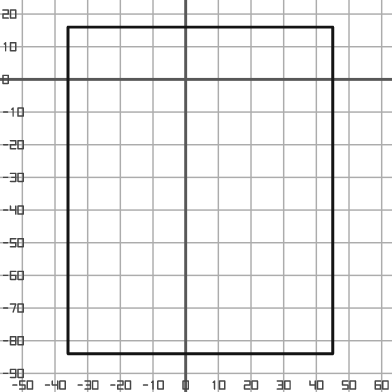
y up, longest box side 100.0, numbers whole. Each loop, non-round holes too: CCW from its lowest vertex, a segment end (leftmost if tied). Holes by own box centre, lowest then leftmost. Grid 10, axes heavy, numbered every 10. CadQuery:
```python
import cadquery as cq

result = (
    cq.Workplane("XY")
    .moveTo(-36.0, -84.0)
    .lineTo(45.0, -84.0)
    .lineTo(45.0, 16.0)
    .lineTo(-36.0, 16.0)
    .close()
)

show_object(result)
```